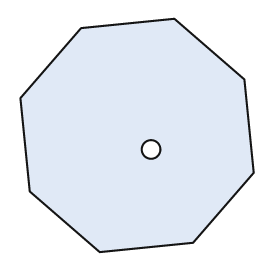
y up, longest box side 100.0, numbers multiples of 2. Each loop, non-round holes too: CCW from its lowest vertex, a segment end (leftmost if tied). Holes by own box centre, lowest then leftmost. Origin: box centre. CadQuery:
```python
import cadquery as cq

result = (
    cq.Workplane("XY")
    .moveTo(-16.0, -50.0)
    .lineTo(24.0, -46.0)
    .lineTo(50.0, -16.0)
    .lineTo(46.0, 24.0)
    .lineTo(16.0, 50.0)
    .lineTo(-24.0, 46.0)
    .lineTo(-50.0, 16.0)
    .lineTo(-46.0, -24.0)
    .close()
    .moveTo(6.0, -6.0)
    .circle(4.0)
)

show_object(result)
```